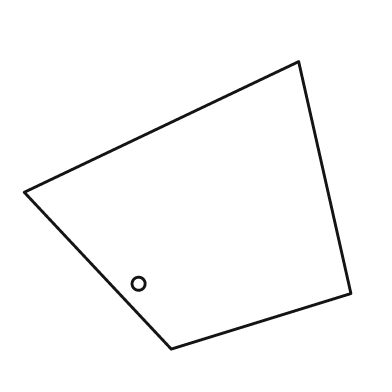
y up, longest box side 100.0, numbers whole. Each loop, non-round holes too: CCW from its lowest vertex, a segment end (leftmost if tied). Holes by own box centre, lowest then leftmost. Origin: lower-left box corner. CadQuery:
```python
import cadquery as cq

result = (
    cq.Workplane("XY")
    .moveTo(45.0, 0.0)
    .lineTo(100.0, 17.0)
    .lineTo(84.0, 88.0)
    .lineTo(0.0, 48.0)
    .close()
    .moveTo(35.0, 20.0)
    .circle(2.0)
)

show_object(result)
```